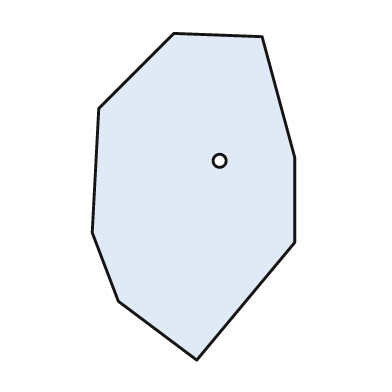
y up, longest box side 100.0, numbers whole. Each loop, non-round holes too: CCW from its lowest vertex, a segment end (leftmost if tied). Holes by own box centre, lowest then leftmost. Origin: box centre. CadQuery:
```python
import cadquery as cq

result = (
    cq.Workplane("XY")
    .moveTo(1.0, -50.0)
    .lineTo(31.0, -14.0)
    .lineTo(31.0, 12.0)
    .lineTo(21.0, 49.0)
    .lineTo(-6.0, 50.0)
    .lineTo(-29.0, 27.0)
    .lineTo(-31.0, -11.0)
    .lineTo(-23.0, -32.0)
    .close()
    .moveTo(8.0, 11.0)
    .circle(2.0)
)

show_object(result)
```